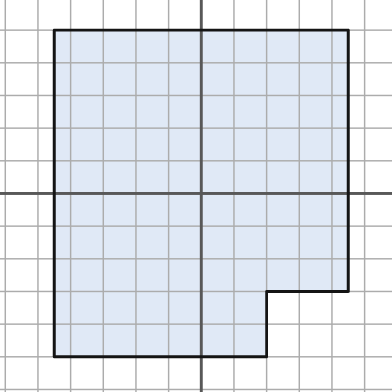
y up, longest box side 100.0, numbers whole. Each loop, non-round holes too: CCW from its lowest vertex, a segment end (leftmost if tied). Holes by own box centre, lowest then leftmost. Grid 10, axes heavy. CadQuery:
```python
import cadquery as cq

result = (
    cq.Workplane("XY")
    .moveTo(-45.0, -50.0)
    .lineTo(20.0, -50.0)
    .lineTo(20.0, -30.0)
    .lineTo(45.0, -30.0)
    .lineTo(45.0, 50.0)
    .lineTo(-45.0, 50.0)
    .close()
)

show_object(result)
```